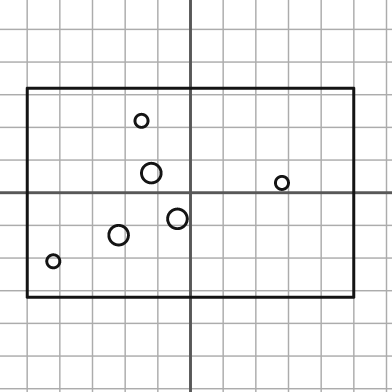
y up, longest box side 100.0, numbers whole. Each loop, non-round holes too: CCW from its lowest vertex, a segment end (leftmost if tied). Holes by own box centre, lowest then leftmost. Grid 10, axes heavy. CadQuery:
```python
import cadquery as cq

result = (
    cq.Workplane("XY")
    .moveTo(-50.0, -32.0)
    .lineTo(50.0, -32.0)
    .lineTo(50.0, 32.0)
    .lineTo(-50.0, 32.0)
    .close()
    .moveTo(-42.0, -21.0)
    .circle(2.0)
    .moveTo(-22.0, -13.0)
    .circle(3.0)
    .moveTo(-4.0, -8.0)
    .circle(3.0)
    .moveTo(28.0, 3.0)
    .circle(2.0)
    .moveTo(-12.0, 6.0)
    .circle(3.0)
    .moveTo(-15.0, 22.0)
    .circle(2.0)
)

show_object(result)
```